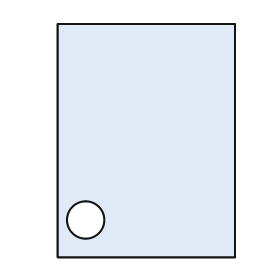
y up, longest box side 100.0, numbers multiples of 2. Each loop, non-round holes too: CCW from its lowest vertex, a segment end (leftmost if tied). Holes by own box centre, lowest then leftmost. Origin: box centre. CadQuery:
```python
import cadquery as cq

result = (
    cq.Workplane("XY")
    .moveTo(-38.0, -50.0)
    .lineTo(38.0, -50.0)
    .lineTo(38.0, 50.0)
    .lineTo(-38.0, 50.0)
    .close()
    .moveTo(-26.0, -34.0)
    .circle(8.0)
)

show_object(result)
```